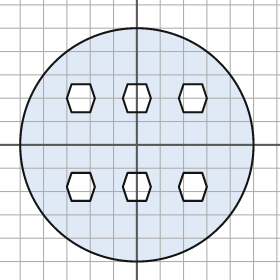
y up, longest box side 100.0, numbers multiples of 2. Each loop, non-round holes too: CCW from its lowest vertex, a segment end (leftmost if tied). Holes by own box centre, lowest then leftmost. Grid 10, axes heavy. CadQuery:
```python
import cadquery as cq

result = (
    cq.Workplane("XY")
    .moveTo(0.0, 0.0)
    .circle(50.0)
    .moveTo(-28.0, -24.0)
    .lineTo(-20.0, -24.0)
    .lineTo(-18.0, -18.0)
    .lineTo(-20.0, -12.0)
    .lineTo(-28.0, -12.0)
    .lineTo(-30.0, -18.0)
    .close()
    .moveTo(-4.0, -24.0)
    .lineTo(4.0, -24.0)
    .lineTo(6.0, -18.0)
    .lineTo(4.0, -12.0)
    .lineTo(-4.0, -12.0)
    .lineTo(-6.0, -18.0)
    .close()
    .moveTo(20.0, -24.0)
    .lineTo(28.0, -24.0)
    .lineTo(30.0, -18.0)
    .lineTo(28.0, -12.0)
    .lineTo(20.0, -12.0)
    .lineTo(18.0, -18.0)
    .close()
    .moveTo(-28.0, 14.0)
    .lineTo(-20.0, 14.0)
    .lineTo(-18.0, 20.0)
    .lineTo(-20.0, 26.0)
    .lineTo(-28.0, 26.0)
    .lineTo(-30.0, 20.0)
    .close()
    .moveTo(-4.0, 14.0)
    .lineTo(4.0, 14.0)
    .lineTo(6.0, 20.0)
    .lineTo(4.0, 26.0)
    .lineTo(-4.0, 26.0)
    .lineTo(-6.0, 20.0)
    .close()
    .moveTo(20.0, 14.0)
    .lineTo(28.0, 14.0)
    .lineTo(30.0, 20.0)
    .lineTo(28.0, 26.0)
    .lineTo(20.0, 26.0)
    .lineTo(18.0, 20.0)
    .close()
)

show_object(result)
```